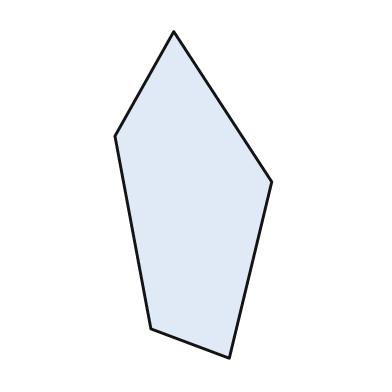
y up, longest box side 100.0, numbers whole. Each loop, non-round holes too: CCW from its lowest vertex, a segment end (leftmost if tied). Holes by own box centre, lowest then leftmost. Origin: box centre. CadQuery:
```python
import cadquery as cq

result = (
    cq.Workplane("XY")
    .moveTo(11.0, -50.0)
    .lineTo(24.0, 4.0)
    .lineTo(-6.0, 50.0)
    .lineTo(-24.0, 18.0)
    .lineTo(-13.0, -41.0)
    .close()
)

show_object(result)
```